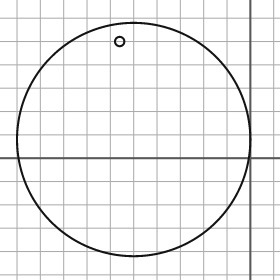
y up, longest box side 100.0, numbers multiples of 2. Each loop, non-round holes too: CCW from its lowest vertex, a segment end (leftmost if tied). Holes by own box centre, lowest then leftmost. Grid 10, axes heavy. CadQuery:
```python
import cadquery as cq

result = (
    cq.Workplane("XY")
    .moveTo(-50.0, 8.0)
    .circle(50.0)
    .moveTo(-56.0, 50.0)
    .circle(2.0)
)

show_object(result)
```